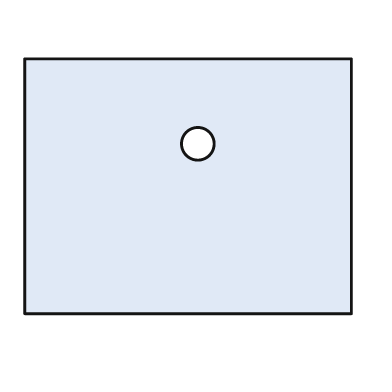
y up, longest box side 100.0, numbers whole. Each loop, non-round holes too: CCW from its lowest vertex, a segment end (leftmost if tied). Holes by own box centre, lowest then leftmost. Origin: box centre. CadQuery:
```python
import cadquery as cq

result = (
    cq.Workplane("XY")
    .moveTo(-50.0, -39.0)
    .lineTo(50.0, -39.0)
    .lineTo(50.0, 39.0)
    .lineTo(-50.0, 39.0)
    .close()
    .moveTo(3.0, 13.0)
    .circle(5.0)
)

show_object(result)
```